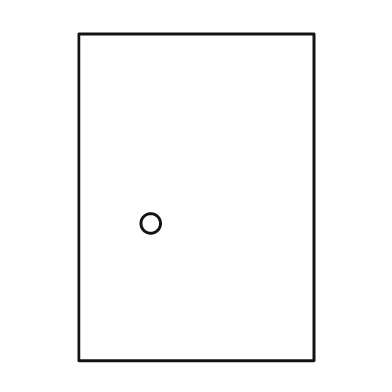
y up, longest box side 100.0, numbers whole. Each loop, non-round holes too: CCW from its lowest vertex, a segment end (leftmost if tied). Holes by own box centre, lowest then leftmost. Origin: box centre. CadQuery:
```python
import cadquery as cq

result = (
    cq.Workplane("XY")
    .moveTo(-36.0, -50.0)
    .lineTo(36.0, -50.0)
    .lineTo(36.0, 50.0)
    .lineTo(-36.0, 50.0)
    .close()
    .moveTo(-14.0, -8.0)
    .circle(3.0)
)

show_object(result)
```